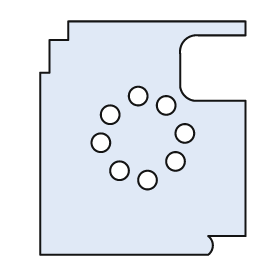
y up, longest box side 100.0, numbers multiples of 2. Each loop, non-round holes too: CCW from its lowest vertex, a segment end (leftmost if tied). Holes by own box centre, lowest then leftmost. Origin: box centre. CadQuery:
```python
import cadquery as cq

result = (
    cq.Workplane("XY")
    .moveTo(-44.0, -50.0)
    .lineTo(28.0, -50.0)
    .threePointArc((30.0, -46.0), (28.0, -42.0))
    .lineTo(44.0, -42.0)
    .lineTo(44.0, 16.0)
    .lineTo(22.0, 16.0)
    .threePointArc((18.0, 18.0), (16.0, 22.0))
    .lineTo(16.0, 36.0)
    .threePointArc((18.0, 42.0), (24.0, 44.0))
    .lineTo(44.0, 44.0)
    .lineTo(44.0, 50.0)
    .lineTo(-32.0, 50.0)
    .lineTo(-32.0, 42.0)
    .lineTo(-40.0, 42.0)
    .lineTo(-40.0, 28.0)
    .lineTo(-44.0, 28.0)
    .close()
    .moveTo(2.0, -18.0)
    .circle(4.0)
    .moveTo(-10.0, -14.0)
    .circle(4.0)
    .moveTo(14.0, -10.0)
    .circle(4.0)
    .moveTo(-18.0, -2.0)
    .circle(4.0)
    .moveTo(18.0, 2.0)
    .circle(4.0)
    .moveTo(-14.0, 10.0)
    .circle(4.0)
    .moveTo(10.0, 14.0)
    .circle(4.0)
    .moveTo(-2.0, 18.0)
    .circle(4.0)
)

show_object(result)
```